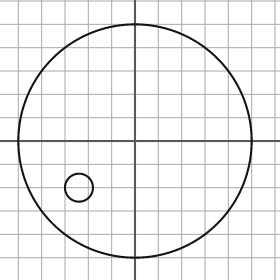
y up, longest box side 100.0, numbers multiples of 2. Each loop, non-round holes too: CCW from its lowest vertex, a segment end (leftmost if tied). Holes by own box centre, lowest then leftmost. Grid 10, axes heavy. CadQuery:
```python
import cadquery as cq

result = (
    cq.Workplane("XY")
    .moveTo(0.0, 0.0)
    .circle(50.0)
    .moveTo(-24.0, -20.0)
    .circle(6.0)
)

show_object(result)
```